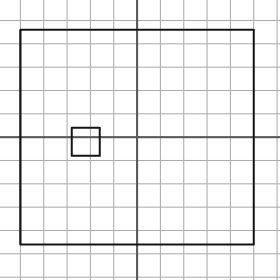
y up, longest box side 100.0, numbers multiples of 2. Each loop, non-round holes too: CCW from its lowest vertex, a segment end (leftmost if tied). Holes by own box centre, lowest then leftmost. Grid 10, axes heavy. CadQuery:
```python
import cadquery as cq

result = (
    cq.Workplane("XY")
    .moveTo(-50.0, -46.0)
    .lineTo(50.0, -46.0)
    .lineTo(50.0, 46.0)
    .lineTo(-50.0, 46.0)
    .close()
    .moveTo(-28.0, -8.0)
    .lineTo(-16.0, -8.0)
    .lineTo(-16.0, 4.0)
    .lineTo(-28.0, 4.0)
    .close()
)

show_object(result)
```